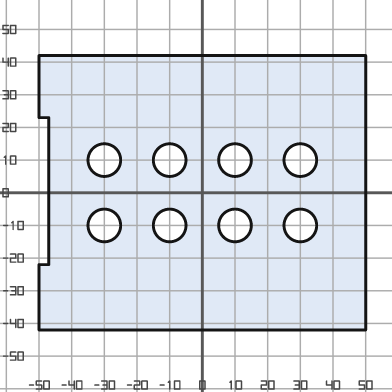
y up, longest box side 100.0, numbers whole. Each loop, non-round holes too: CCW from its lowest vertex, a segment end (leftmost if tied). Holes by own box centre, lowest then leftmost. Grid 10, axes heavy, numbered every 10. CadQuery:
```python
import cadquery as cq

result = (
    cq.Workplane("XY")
    .moveTo(-50.0, -42.0)
    .lineTo(50.0, -42.0)
    .lineTo(50.0, 42.0)
    .lineTo(-50.0, 42.0)
    .lineTo(-50.0, 23.0)
    .lineTo(-47.0, 23.0)
    .lineTo(-47.0, -22.0)
    .lineTo(-50.0, -22.0)
    .close()
    .moveTo(-30.0, -10.0)
    .circle(5.0)
    .moveTo(-10.0, -10.0)
    .circle(5.0)
    .moveTo(10.0, -10.0)
    .circle(5.0)
    .moveTo(30.0, -10.0)
    .circle(5.0)
    .moveTo(-30.0, 10.0)
    .circle(5.0)
    .moveTo(-10.0, 10.0)
    .circle(5.0)
    .moveTo(10.0, 10.0)
    .circle(5.0)
    .moveTo(30.0, 10.0)
    .circle(5.0)
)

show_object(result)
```